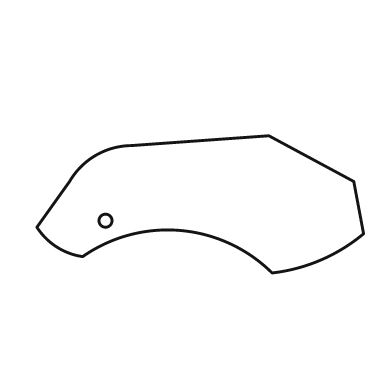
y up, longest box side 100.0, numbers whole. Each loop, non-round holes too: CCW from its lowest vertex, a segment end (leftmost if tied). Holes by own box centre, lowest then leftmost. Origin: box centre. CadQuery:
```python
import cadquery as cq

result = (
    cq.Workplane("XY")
    .moveTo(22.0, -21.0)
    .threePointArc((37.0, -17.0), (50.0, -9.0))
    .lineTo(47.0, 7.0)
    .lineTo(21.0, 21.0)
    .lineTo(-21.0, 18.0)
    .threePointArc((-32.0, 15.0), (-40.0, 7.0))
    .lineTo(-50.0, -7.0)
    .threePointArc((-44.0, -13.0), (-36.0, -16.0))
    .threePointArc((-6.0, -8.0), (22.0, -21.0))
    .close()
    .moveTo(-29.0, -5.0)
    .circle(2.0)
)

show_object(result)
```